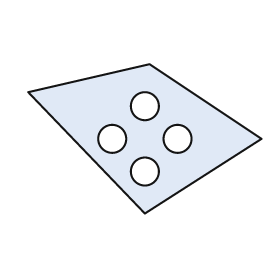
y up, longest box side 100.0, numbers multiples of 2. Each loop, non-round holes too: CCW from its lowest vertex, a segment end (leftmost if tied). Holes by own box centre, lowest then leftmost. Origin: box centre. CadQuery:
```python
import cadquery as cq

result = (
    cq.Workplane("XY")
    .moveTo(0.0, -32.0)
    .lineTo(50.0, 0.0)
    .lineTo(2.0, 32.0)
    .lineTo(-50.0, 20.0)
    .close()
    .moveTo(0.0, -14.0)
    .circle(6.0)
    .moveTo(-14.0, 0.0)
    .circle(6.0)
    .moveTo(14.0, 0.0)
    .circle(6.0)
    .moveTo(0.0, 14.0)
    .circle(6.0)
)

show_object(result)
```